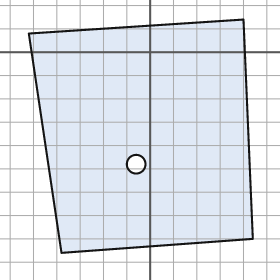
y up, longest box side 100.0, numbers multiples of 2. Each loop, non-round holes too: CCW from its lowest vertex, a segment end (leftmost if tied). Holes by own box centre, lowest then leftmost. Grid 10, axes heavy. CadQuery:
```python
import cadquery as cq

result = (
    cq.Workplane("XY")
    .moveTo(-38.0, -86.0)
    .lineTo(44.0, -80.0)
    .lineTo(40.0, 14.0)
    .lineTo(-52.0, 8.0)
    .close()
    .moveTo(-6.0, -48.0)
    .circle(4.0)
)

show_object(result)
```